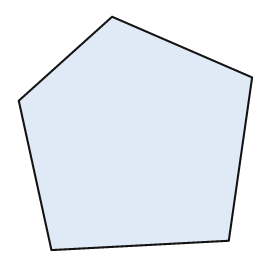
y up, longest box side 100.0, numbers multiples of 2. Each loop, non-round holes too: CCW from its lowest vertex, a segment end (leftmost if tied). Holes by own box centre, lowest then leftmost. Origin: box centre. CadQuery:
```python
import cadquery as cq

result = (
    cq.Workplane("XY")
    .moveTo(-36.0, -50.0)
    .lineTo(40.0, -46.0)
    .lineTo(50.0, 24.0)
    .lineTo(-10.0, 50.0)
    .lineTo(-50.0, 14.0)
    .close()
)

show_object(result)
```